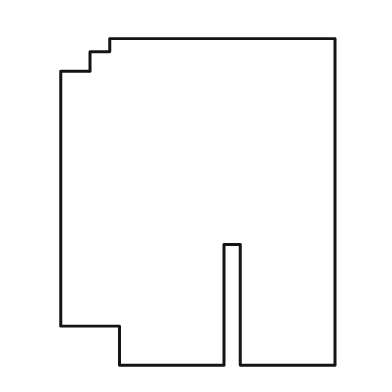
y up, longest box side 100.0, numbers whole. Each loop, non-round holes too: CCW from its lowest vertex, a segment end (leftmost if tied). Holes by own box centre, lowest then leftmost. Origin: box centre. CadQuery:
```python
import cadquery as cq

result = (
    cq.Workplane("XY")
    .moveTo(-24.0, -50.0)
    .lineTo(8.0, -50.0)
    .lineTo(8.0, -13.0)
    .lineTo(13.0, -13.0)
    .lineTo(13.0, -50.0)
    .lineTo(42.0, -50.0)
    .lineTo(42.0, 50.0)
    .lineTo(-27.0, 50.0)
    .lineTo(-27.0, 46.0)
    .lineTo(-33.0, 46.0)
    .lineTo(-33.0, 40.0)
    .lineTo(-42.0, 40.0)
    .lineTo(-42.0, -38.0)
    .lineTo(-24.0, -38.0)
    .close()
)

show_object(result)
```